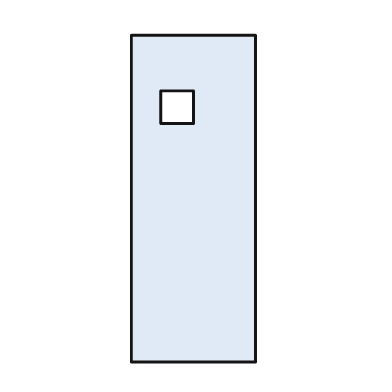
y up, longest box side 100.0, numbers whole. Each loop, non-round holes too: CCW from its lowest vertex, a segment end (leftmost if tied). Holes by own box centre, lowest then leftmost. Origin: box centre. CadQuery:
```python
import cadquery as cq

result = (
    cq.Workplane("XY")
    .moveTo(-19.0, -50.0)
    .lineTo(19.0, -50.0)
    .lineTo(19.0, 50.0)
    .lineTo(-19.0, 50.0)
    .close()
    .moveTo(-10.0, 23.0)
    .lineTo(0.0, 23.0)
    .lineTo(0.0, 33.0)
    .lineTo(-10.0, 33.0)
    .close()
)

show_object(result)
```